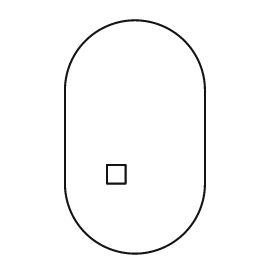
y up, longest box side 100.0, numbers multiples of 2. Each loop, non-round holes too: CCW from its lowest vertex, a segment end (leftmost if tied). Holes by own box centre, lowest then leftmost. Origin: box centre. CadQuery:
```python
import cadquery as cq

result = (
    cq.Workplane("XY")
    .moveTo(-30.0, -20.0)
    .threePointArc((0.0, -50.0), (30.0, -20.0))
    .lineTo(30.0, 20.0)
    .threePointArc((0.0, 50.0), (-30.0, 20.0))
    .close()
    .moveTo(-12.0, -20.0)
    .lineTo(-4.0, -20.0)
    .lineTo(-4.0, -12.0)
    .lineTo(-12.0, -12.0)
    .close()
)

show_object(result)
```